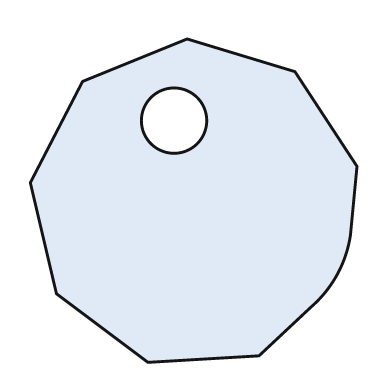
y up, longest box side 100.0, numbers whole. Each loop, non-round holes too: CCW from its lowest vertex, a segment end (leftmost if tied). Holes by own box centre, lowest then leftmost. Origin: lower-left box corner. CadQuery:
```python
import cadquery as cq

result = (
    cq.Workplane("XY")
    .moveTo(36.0, 0.0)
    .lineTo(70.0, 2.0)
    .lineTo(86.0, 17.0)
    .threePointArc((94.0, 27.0), (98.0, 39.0))
    .lineTo(100.0, 60.0)
    .lineTo(81.0, 89.0)
    .lineTo(48.0, 99.0)
    .lineTo(16.0, 86.0)
    .lineTo(0.0, 55.0)
    .lineTo(8.0, 21.0)
    .close()
    .moveTo(44.0, 74.0)
    .circle(10.0)
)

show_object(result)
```